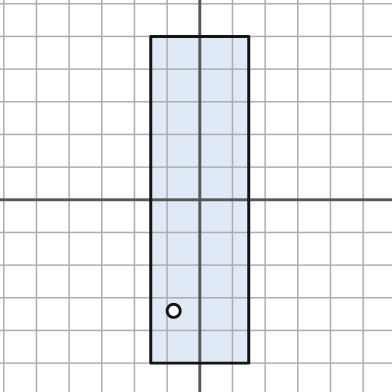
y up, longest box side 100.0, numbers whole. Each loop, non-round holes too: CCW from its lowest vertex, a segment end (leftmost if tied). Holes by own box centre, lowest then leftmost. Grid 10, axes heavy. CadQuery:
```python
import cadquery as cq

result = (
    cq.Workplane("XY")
    .moveTo(-15.0, -50.0)
    .lineTo(15.0, -50.0)
    .lineTo(15.0, 50.0)
    .lineTo(-15.0, 50.0)
    .close()
    .moveTo(-8.0, -34.0)
    .circle(2.0)
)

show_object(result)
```